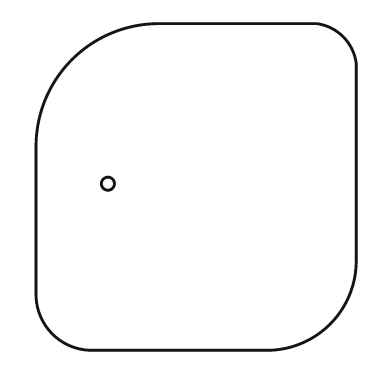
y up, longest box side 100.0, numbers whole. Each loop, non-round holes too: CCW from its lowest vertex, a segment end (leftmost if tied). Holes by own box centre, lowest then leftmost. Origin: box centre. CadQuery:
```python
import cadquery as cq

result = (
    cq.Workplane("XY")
    .moveTo(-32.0, -50.0)
    .lineTo(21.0, -50.0)
    .threePointArc((41.0, -42.0), (49.0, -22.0))
    .lineTo(49.0, 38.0)
    .threePointArc((45.0, 46.0), (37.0, 50.0))
    .lineTo(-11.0, 50.0)
    .threePointArc((-38.0, 39.0), (-49.0, 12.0))
    .lineTo(-49.0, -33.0)
    .threePointArc((-44.0, -45.0), (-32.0, -50.0))
    .close()
    .moveTo(-27.0, 1.0)
    .circle(2.0)
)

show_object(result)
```